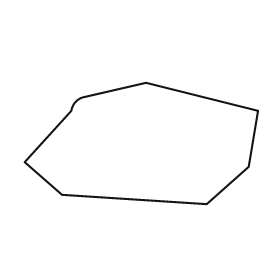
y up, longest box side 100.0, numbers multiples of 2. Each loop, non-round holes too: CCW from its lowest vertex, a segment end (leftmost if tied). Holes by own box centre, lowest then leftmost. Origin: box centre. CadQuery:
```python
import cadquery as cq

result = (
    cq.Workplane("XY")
    .moveTo(28.0, -26.0)
    .lineTo(46.0, -10.0)
    .lineTo(50.0, 14.0)
    .lineTo(2.0, 26.0)
    .lineTo(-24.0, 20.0)
    .threePointArc((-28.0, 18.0), (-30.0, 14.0))
    .lineTo(-50.0, -8.0)
    .lineTo(-34.0, -22.0)
    .close()
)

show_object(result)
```